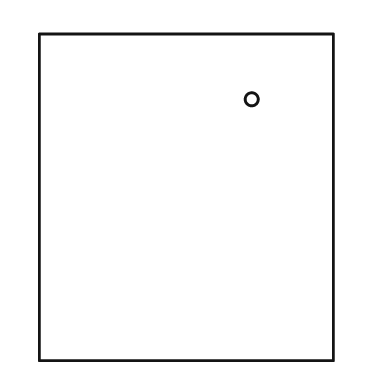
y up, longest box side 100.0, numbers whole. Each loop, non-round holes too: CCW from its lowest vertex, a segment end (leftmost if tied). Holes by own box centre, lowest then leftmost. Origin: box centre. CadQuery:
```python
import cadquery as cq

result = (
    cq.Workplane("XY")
    .moveTo(-45.0, -50.0)
    .lineTo(45.0, -50.0)
    .lineTo(45.0, 50.0)
    .lineTo(-45.0, 50.0)
    .close()
    .moveTo(20.0, 30.0)
    .circle(2.0)
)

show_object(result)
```